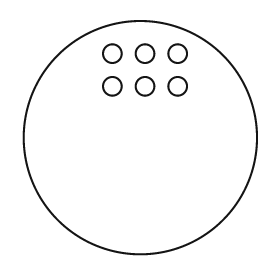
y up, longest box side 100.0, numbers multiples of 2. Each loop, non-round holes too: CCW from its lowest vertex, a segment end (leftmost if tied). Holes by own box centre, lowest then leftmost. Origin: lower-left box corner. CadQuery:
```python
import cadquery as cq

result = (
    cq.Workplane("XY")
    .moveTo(50.0, 50.0)
    .circle(50.0)
    .moveTo(38.0, 72.0)
    .circle(4.0)
    .moveTo(52.0, 72.0)
    .circle(4.0)
    .moveTo(66.0, 72.0)
    .circle(4.0)
    .moveTo(38.0, 86.0)
    .circle(4.0)
    .moveTo(52.0, 86.0)
    .circle(4.0)
    .moveTo(66.0, 86.0)
    .circle(4.0)
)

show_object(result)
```